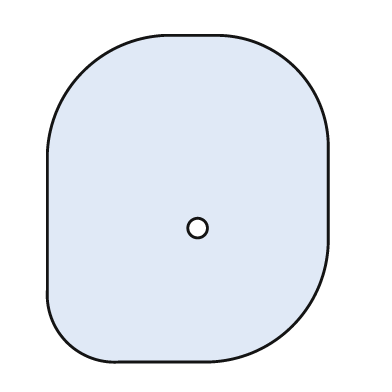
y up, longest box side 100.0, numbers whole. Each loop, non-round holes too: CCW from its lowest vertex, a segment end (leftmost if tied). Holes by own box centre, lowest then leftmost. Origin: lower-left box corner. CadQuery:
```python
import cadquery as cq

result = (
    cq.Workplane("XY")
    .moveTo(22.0, 0.0)
    .lineTo(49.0, 0.0)
    .threePointArc((75.0, 11.0), (86.0, 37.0))
    .lineTo(86.0, 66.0)
    .threePointArc((76.0, 90.0), (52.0, 100.0))
    .lineTo(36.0, 100.0)
    .threePointArc((11.0, 89.0), (0.0, 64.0))
    .lineTo(0.0, 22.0)
    .threePointArc((6.0, 6.0), (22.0, 0.0))
    .close()
    .moveTo(46.0, 41.0)
    .circle(3.0)
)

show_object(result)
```